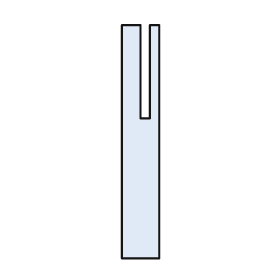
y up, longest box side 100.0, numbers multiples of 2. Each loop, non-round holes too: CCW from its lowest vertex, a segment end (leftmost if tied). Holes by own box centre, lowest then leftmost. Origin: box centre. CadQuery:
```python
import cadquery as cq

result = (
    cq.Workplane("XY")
    .moveTo(-8.0, -50.0)
    .lineTo(8.0, -50.0)
    .lineTo(8.0, 50.0)
    .lineTo(4.0, 50.0)
    .lineTo(4.0, 10.0)
    .lineTo(0.0, 10.0)
    .lineTo(0.0, 50.0)
    .lineTo(-8.0, 50.0)
    .close()
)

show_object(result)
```